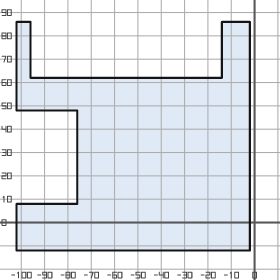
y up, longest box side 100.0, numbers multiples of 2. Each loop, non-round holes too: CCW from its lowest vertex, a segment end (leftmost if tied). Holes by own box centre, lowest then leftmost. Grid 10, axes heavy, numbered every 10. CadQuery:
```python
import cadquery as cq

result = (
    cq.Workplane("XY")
    .moveTo(-102.0, -12.0)
    .lineTo(-2.0, -12.0)
    .lineTo(-2.0, 86.0)
    .lineTo(-14.0, 86.0)
    .lineTo(-14.0, 62.0)
    .lineTo(-96.0, 62.0)
    .lineTo(-96.0, 86.0)
    .lineTo(-102.0, 86.0)
    .lineTo(-102.0, 48.0)
    .lineTo(-76.0, 48.0)
    .lineTo(-76.0, 8.0)
    .lineTo(-102.0, 8.0)
    .close()
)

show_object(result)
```